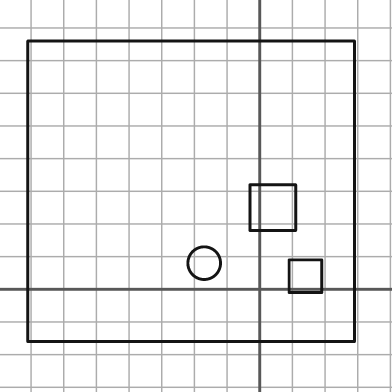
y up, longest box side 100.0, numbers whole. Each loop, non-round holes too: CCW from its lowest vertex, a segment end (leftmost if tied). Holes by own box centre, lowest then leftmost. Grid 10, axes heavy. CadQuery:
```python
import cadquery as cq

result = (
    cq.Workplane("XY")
    .moveTo(-71.0, -16.0)
    .lineTo(29.0, -16.0)
    .lineTo(29.0, 76.0)
    .lineTo(-71.0, 76.0)
    .close()
    .moveTo(9.0, -1.0)
    .lineTo(19.0, -1.0)
    .lineTo(19.0, 9.0)
    .lineTo(9.0, 9.0)
    .close()
    .moveTo(-17.0, 8.0)
    .circle(5.0)
    .moveTo(-3.0, 18.0)
    .lineTo(11.0, 18.0)
    .lineTo(11.0, 32.0)
    .lineTo(-3.0, 32.0)
    .close()
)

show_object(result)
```